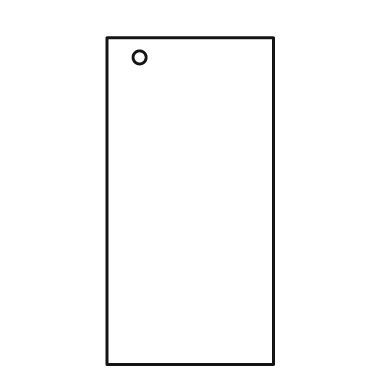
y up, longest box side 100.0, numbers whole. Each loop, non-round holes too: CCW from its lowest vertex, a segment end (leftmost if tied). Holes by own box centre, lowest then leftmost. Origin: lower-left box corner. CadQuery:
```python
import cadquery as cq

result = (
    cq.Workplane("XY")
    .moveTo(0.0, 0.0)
    .lineTo(51.0, 0.0)
    .lineTo(51.0, 100.0)
    .lineTo(0.0, 100.0)
    .close()
    .moveTo(10.0, 94.0)
    .circle(2.0)
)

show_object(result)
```